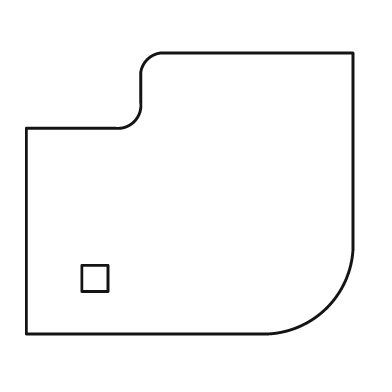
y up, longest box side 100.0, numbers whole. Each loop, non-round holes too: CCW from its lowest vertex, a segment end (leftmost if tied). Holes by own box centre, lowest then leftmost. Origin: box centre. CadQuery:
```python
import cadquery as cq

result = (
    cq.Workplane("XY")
    .moveTo(-50.0, -43.0)
    .lineTo(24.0, -43.0)
    .threePointArc((42.0, -35.0), (50.0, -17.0))
    .lineTo(50.0, 43.0)
    .lineTo(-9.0, 43.0)
    .threePointArc((-13.0, 41.0), (-15.0, 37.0))
    .lineTo(-15.0, 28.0)
    .threePointArc((-17.0, 22.0), (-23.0, 20.0))
    .lineTo(-50.0, 20.0)
    .close()
    .moveTo(-33.0, -30.0)
    .lineTo(-25.0, -30.0)
    .lineTo(-25.0, -22.0)
    .lineTo(-33.0, -22.0)
    .close()
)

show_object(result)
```